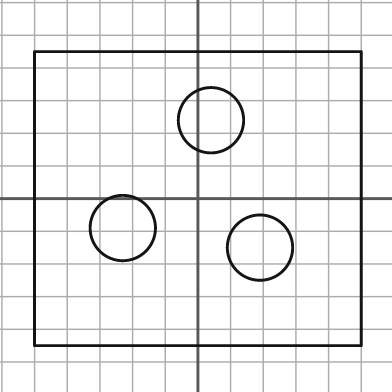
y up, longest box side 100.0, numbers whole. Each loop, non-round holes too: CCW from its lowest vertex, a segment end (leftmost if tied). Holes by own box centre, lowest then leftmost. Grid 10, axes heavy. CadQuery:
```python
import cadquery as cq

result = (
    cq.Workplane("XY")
    .moveTo(-50.0, -45.0)
    .lineTo(50.0, -45.0)
    .lineTo(50.0, 45.0)
    .lineTo(-50.0, 45.0)
    .close()
    .moveTo(19.0, -15.0)
    .circle(10.0)
    .moveTo(-23.0, -9.0)
    .circle(10.0)
    .moveTo(4.0, 24.0)
    .circle(10.0)
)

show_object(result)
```